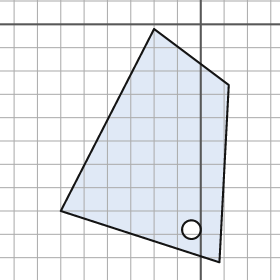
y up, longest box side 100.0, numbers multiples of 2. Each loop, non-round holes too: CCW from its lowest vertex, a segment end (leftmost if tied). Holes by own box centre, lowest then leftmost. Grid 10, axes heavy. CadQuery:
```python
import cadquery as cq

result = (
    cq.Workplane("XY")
    .moveTo(8.0, -102.0)
    .lineTo(12.0, -26.0)
    .lineTo(-20.0, -2.0)
    .lineTo(-60.0, -80.0)
    .close()
    .moveTo(-4.0, -88.0)
    .circle(4.0)
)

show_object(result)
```